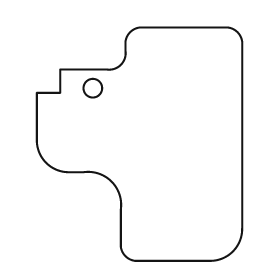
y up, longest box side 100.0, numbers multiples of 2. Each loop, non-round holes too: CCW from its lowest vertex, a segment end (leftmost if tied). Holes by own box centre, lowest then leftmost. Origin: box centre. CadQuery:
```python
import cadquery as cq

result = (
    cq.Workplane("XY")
    .moveTo(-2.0, -50.0)
    .lineTo(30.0, -50.0)
    .threePointArc((40.0, -46.0), (44.0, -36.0))
    .lineTo(44.0, 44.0)
    .threePointArc((42.0, 48.0), (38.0, 50.0))
    .lineTo(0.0, 50.0)
    .threePointArc((-4.0, 48.0), (-6.0, 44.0))
    .lineTo(-6.0, 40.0)
    .threePointArc((-8.0, 34.0), (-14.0, 32.0))
    .lineTo(-34.0, 32.0)
    .lineTo(-34.0, 22.0)
    .lineTo(-44.0, 22.0)
    .lineTo(-44.0, 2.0)
    .threePointArc((-40.0, -8.0), (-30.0, -12.0))
    .lineTo(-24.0, -12.0)
    .threePointArc((-12.0, -16.0), (-8.0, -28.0))
    .lineTo(-8.0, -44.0)
    .threePointArc((-6.0, -48.0), (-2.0, -50.0))
    .close()
    .moveTo(-20.0, 24.0)
    .circle(4.0)
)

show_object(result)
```